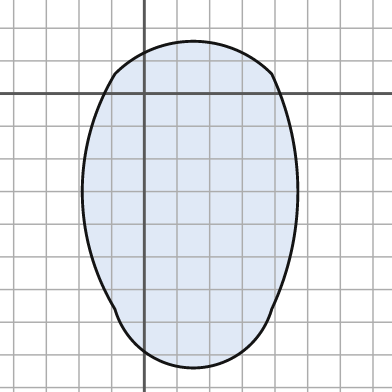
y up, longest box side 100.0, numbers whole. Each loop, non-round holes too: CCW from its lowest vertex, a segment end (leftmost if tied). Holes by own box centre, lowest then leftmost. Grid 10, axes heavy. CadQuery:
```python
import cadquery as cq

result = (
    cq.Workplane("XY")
    .moveTo(-9.0, -66.0)
    .threePointArc((15.0, -84.0), (39.0, -66.0))
    .threePointArc((47.0, -30.0), (39.0, 6.0))
    .threePointArc((15.0, 16.0), (-9.0, 6.0))
    .threePointArc((-19.0, -30.0), (-9.0, -66.0))
    .close()
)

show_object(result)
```